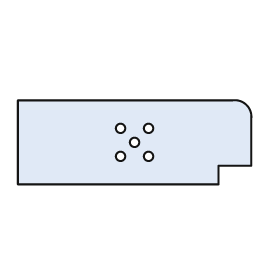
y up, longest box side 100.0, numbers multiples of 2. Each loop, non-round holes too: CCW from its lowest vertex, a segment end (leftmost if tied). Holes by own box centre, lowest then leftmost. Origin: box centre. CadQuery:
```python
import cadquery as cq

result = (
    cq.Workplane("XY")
    .moveTo(-50.0, -18.0)
    .lineTo(36.0, -18.0)
    .lineTo(36.0, -10.0)
    .lineTo(50.0, -10.0)
    .lineTo(50.0, 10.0)
    .threePointArc((48.0, 16.0), (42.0, 18.0))
    .lineTo(-50.0, 18.0)
    .close()
    .moveTo(-6.0, -6.0)
    .circle(2.0)
    .moveTo(6.0, -6.0)
    .circle(2.0)
    .moveTo(0.0, 0.0)
    .circle(2.0)
    .moveTo(-6.0, 6.0)
    .circle(2.0)
    .moveTo(6.0, 6.0)
    .circle(2.0)
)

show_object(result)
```